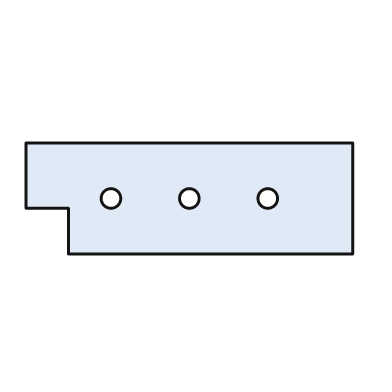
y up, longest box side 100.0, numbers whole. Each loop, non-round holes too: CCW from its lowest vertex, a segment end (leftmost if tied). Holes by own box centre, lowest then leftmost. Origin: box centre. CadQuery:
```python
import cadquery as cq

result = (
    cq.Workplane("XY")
    .moveTo(-37.0, -17.0)
    .lineTo(50.0, -17.0)
    .lineTo(50.0, 17.0)
    .lineTo(-50.0, 17.0)
    .lineTo(-50.0, -3.0)
    .lineTo(-37.0, -3.0)
    .close()
    .moveTo(-24.0, 0.0)
    .circle(3.0)
    .moveTo(0.0, 0.0)
    .circle(3.0)
    .moveTo(24.0, 0.0)
    .circle(3.0)
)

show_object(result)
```